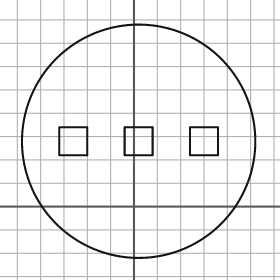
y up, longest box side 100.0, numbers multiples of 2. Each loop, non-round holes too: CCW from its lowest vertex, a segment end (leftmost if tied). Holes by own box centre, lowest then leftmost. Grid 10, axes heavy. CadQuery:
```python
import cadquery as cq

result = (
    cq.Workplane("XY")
    .moveTo(2.0, 28.0)
    .circle(50.0)
    .moveTo(-32.0, 22.0)
    .lineTo(-20.0, 22.0)
    .lineTo(-20.0, 34.0)
    .lineTo(-32.0, 34.0)
    .close()
    .moveTo(-4.0, 22.0)
    .lineTo(8.0, 22.0)
    .lineTo(8.0, 34.0)
    .lineTo(-4.0, 34.0)
    .close()
    .moveTo(24.0, 22.0)
    .lineTo(36.0, 22.0)
    .lineTo(36.0, 34.0)
    .lineTo(24.0, 34.0)
    .close()
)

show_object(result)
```